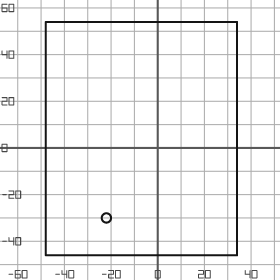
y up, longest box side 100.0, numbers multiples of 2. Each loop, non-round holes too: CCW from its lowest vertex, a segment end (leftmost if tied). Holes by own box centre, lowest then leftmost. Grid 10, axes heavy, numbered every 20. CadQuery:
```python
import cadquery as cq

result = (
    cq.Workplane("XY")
    .moveTo(-48.0, -46.0)
    .lineTo(34.0, -46.0)
    .lineTo(34.0, 54.0)
    .lineTo(-48.0, 54.0)
    .close()
    .moveTo(-22.0, -30.0)
    .circle(2.0)
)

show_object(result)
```